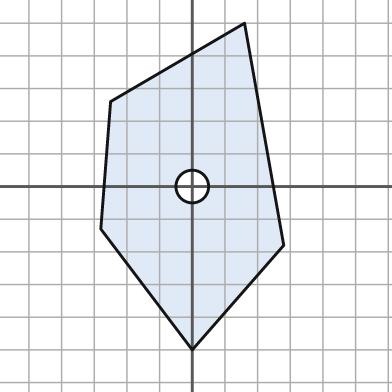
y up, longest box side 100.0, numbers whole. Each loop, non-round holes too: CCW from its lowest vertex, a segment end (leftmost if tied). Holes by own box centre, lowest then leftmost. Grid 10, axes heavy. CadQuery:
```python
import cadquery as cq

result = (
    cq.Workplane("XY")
    .moveTo(0.0, -50.0)
    .lineTo(28.0, -18.0)
    .lineTo(16.0, 50.0)
    .lineTo(-25.0, 26.0)
    .lineTo(-28.0, -13.0)
    .close()
    .moveTo(0.0, 0.0)
    .circle(5.0)
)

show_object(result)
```